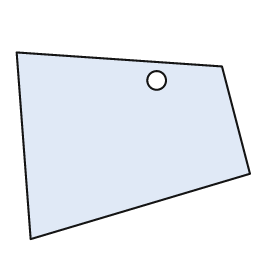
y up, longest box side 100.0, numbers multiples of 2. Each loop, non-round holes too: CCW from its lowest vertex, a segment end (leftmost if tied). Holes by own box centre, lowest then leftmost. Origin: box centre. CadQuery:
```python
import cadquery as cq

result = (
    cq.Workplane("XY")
    .moveTo(-44.0, -40.0)
    .lineTo(50.0, -12.0)
    .lineTo(38.0, 34.0)
    .lineTo(-50.0, 40.0)
    .close()
    .moveTo(10.0, 28.0)
    .circle(4.0)
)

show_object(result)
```